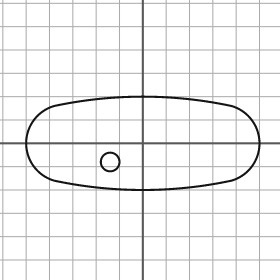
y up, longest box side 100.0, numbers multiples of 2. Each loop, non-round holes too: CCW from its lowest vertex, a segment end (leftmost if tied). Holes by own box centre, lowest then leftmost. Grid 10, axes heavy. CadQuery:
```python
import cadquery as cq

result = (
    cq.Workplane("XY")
    .moveTo(-38.0, -16.0)
    .threePointArc((0.0, -20.0), (38.0, -16.0))
    .threePointArc((50.0, 0.0), (38.0, 16.0))
    .threePointArc((0.0, 20.0), (-38.0, 16.0))
    .threePointArc((-50.0, 0.0), (-38.0, -16.0))
    .close()
    .moveTo(-14.0, -8.0)
    .circle(4.0)
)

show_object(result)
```